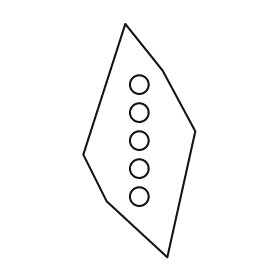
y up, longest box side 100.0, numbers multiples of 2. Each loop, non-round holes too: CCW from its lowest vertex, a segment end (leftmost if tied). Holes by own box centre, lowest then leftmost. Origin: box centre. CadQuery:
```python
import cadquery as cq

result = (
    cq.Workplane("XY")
    .moveTo(12.0, -50.0)
    .lineTo(24.0, 4.0)
    .lineTo(10.0, 30.0)
    .lineTo(-6.0, 50.0)
    .lineTo(-24.0, -6.0)
    .lineTo(-14.0, -26.0)
    .close()
    .moveTo(0.0, -24.0)
    .circle(4.0)
    .moveTo(0.0, -12.0)
    .circle(4.0)
    .moveTo(0.0, 0.0)
    .circle(4.0)
    .moveTo(0.0, 12.0)
    .circle(4.0)
    .moveTo(0.0, 24.0)
    .circle(4.0)
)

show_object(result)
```